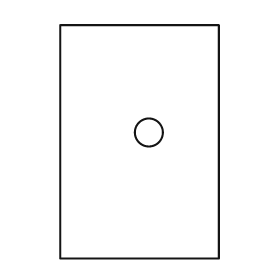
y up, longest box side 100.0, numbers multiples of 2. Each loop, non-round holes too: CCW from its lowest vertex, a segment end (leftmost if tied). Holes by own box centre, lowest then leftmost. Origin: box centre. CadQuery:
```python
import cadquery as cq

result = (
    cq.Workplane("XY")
    .moveTo(-34.0, -50.0)
    .lineTo(34.0, -50.0)
    .lineTo(34.0, 50.0)
    .lineTo(-34.0, 50.0)
    .close()
    .moveTo(4.0, 4.0)
    .circle(6.0)
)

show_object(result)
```